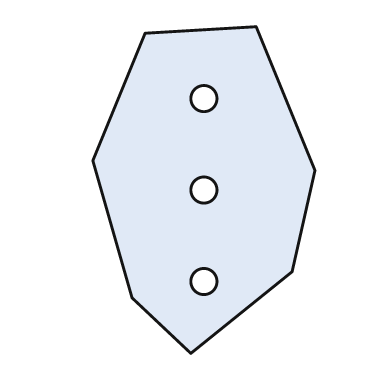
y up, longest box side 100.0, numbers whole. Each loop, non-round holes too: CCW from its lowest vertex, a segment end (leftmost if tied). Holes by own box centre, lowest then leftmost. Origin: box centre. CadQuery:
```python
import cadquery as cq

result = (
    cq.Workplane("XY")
    .moveTo(-4.0, -50.0)
    .lineTo(27.0, -25.0)
    .lineTo(34.0, 6.0)
    .lineTo(16.0, 50.0)
    .lineTo(-18.0, 48.0)
    .lineTo(-34.0, 9.0)
    .lineTo(-22.0, -33.0)
    .close()
    .moveTo(0.0, -28.0)
    .circle(4.0)
    .moveTo(0.0, 0.0)
    .circle(4.0)
    .moveTo(0.0, 28.0)
    .circle(4.0)
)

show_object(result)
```